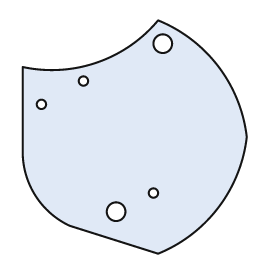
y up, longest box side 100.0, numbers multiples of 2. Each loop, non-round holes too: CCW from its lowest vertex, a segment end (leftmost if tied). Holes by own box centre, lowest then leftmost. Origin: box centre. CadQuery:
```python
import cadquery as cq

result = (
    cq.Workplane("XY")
    .moveTo(10.0, -50.0)
    .threePointArc((36.0, -30.0), (48.0, 0.0))
    .threePointArc((36.0, 30.0), (10.0, 50.0))
    .threePointArc((-16.0, 32.0), (-48.0, 30.0))
    .lineTo(-48.0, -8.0)
    .threePointArc((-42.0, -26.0), (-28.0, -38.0))
    .close()
    .moveTo(-8.0, -32.0)
    .circle(4.0)
    .moveTo(8.0, -24.0)
    .circle(2.0)
    .moveTo(-40.0, 14.0)
    .circle(2.0)
    .moveTo(-22.0, 24.0)
    .circle(2.0)
    .moveTo(12.0, 40.0)
    .circle(4.0)
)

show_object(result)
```